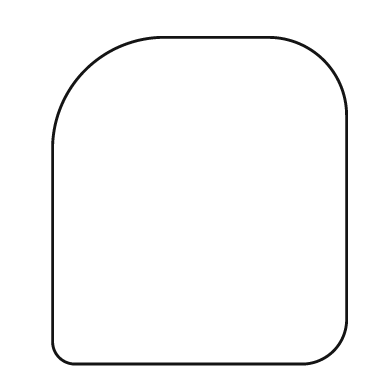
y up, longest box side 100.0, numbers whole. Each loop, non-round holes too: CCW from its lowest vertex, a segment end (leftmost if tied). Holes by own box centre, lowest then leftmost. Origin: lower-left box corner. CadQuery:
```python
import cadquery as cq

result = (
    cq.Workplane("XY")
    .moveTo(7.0, 0.0)
    .lineTo(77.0, 0.0)
    .threePointArc((86.0, 4.0), (90.0, 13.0))
    .lineTo(90.0, 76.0)
    .threePointArc((83.0, 93.0), (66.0, 100.0))
    .lineTo(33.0, 100.0)
    .threePointArc((10.0, 90.0), (0.0, 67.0))
    .lineTo(0.0, 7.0)
    .threePointArc((2.0, 2.0), (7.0, 0.0))
    .close()
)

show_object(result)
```